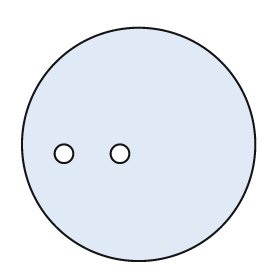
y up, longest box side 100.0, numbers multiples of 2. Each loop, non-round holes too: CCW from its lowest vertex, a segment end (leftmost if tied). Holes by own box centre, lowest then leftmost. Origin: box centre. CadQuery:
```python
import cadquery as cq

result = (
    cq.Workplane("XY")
    .moveTo(0.0, 0.0)
    .circle(50.0)
    .moveTo(-32.0, -4.0)
    .circle(4.0)
    .moveTo(-8.0, -4.0)
    .circle(4.0)
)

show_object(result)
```